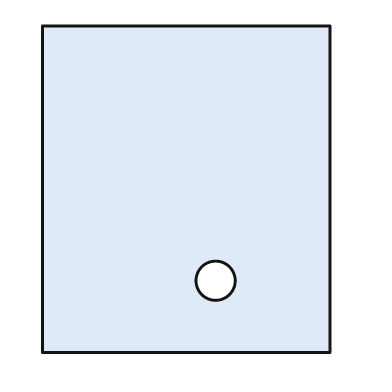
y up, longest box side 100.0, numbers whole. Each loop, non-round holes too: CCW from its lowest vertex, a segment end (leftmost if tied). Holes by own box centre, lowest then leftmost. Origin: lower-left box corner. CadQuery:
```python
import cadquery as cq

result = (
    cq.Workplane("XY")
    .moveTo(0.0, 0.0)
    .lineTo(88.0, 0.0)
    .lineTo(88.0, 100.0)
    .lineTo(0.0, 100.0)
    .close()
    .moveTo(53.0, 22.0)
    .circle(6.0)
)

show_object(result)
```